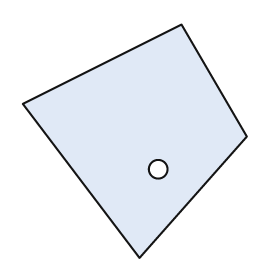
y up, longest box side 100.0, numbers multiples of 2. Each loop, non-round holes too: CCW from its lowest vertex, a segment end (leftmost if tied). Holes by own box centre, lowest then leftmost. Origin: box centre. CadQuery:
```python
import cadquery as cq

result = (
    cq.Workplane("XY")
    .moveTo(2.0, -50.0)
    .lineTo(48.0, 2.0)
    .lineTo(20.0, 50.0)
    .lineTo(-48.0, 16.0)
    .close()
    .moveTo(10.0, -12.0)
    .circle(4.0)
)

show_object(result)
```